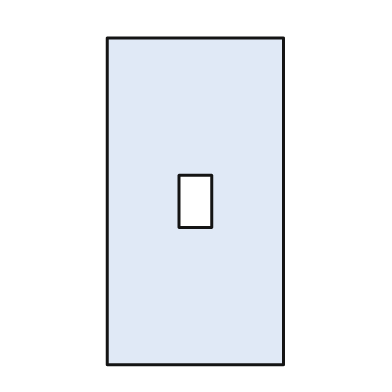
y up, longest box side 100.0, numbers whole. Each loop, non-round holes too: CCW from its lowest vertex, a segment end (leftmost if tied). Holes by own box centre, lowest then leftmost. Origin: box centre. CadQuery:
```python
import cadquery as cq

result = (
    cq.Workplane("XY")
    .moveTo(-27.0, -50.0)
    .lineTo(27.0, -50.0)
    .lineTo(27.0, 50.0)
    .lineTo(-27.0, 50.0)
    .close()
    .moveTo(-5.0, -8.0)
    .lineTo(5.0, -8.0)
    .lineTo(5.0, 8.0)
    .lineTo(-5.0, 8.0)
    .close()
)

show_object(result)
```